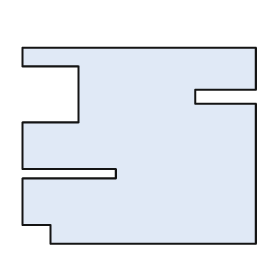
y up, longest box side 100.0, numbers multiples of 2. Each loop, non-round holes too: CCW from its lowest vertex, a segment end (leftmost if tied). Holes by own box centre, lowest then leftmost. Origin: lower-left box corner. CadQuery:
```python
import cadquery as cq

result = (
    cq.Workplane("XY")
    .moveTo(12.0, 0.0)
    .lineTo(100.0, 0.0)
    .lineTo(100.0, 60.0)
    .lineTo(74.0, 60.0)
    .lineTo(74.0, 66.0)
    .lineTo(100.0, 66.0)
    .lineTo(100.0, 84.0)
    .lineTo(0.0, 84.0)
    .lineTo(0.0, 76.0)
    .lineTo(24.0, 76.0)
    .lineTo(24.0, 52.0)
    .lineTo(0.0, 52.0)
    .lineTo(0.0, 32.0)
    .lineTo(40.0, 32.0)
    .lineTo(40.0, 28.0)
    .lineTo(0.0, 28.0)
    .lineTo(0.0, 8.0)
    .lineTo(12.0, 8.0)
    .close()
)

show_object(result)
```